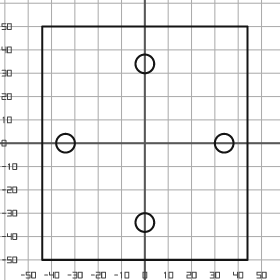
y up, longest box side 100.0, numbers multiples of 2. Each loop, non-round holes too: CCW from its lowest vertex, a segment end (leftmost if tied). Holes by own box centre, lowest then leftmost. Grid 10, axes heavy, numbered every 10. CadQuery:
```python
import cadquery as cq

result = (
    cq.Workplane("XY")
    .moveTo(-44.0, -50.0)
    .lineTo(44.0, -50.0)
    .lineTo(44.0, 50.0)
    .lineTo(-44.0, 50.0)
    .close()
    .moveTo(0.0, -34.0)
    .circle(4.0)
    .moveTo(-34.0, 0.0)
    .circle(4.0)
    .moveTo(34.0, 0.0)
    .circle(4.0)
    .moveTo(0.0, 34.0)
    .circle(4.0)
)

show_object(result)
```